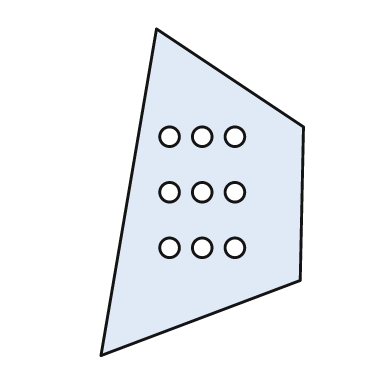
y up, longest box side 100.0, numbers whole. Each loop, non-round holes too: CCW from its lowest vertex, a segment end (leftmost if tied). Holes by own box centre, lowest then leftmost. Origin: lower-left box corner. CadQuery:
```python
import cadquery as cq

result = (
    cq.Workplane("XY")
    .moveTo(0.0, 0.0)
    .lineTo(61.0, 23.0)
    .lineTo(62.0, 70.0)
    .lineTo(17.0, 100.0)
    .close()
    .moveTo(21.0, 33.0)
    .circle(3.0)
    .moveTo(31.0, 33.0)
    .circle(3.0)
    .moveTo(41.0, 33.0)
    .circle(3.0)
    .moveTo(21.0, 50.0)
    .circle(3.0)
    .moveTo(31.0, 50.0)
    .circle(3.0)
    .moveTo(41.0, 50.0)
    .circle(3.0)
    .moveTo(21.0, 67.0)
    .circle(3.0)
    .moveTo(31.0, 67.0)
    .circle(3.0)
    .moveTo(41.0, 67.0)
    .circle(3.0)
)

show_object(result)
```